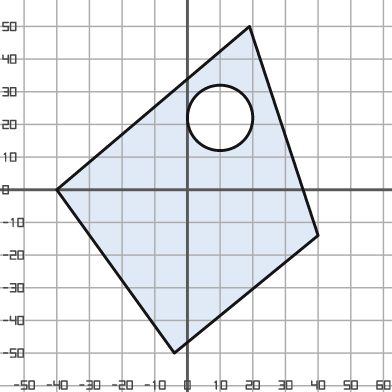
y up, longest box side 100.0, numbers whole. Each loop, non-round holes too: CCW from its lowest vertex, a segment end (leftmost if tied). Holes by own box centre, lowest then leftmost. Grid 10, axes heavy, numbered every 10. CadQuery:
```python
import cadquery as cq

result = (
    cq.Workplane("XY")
    .moveTo(-4.0, -50.0)
    .lineTo(40.0, -14.0)
    .lineTo(19.0, 50.0)
    .lineTo(-40.0, 0.0)
    .close()
    .moveTo(10.0, 22.0)
    .circle(10.0)
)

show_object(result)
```